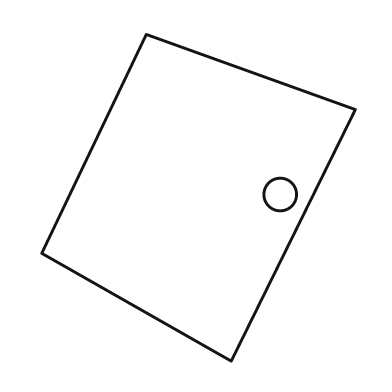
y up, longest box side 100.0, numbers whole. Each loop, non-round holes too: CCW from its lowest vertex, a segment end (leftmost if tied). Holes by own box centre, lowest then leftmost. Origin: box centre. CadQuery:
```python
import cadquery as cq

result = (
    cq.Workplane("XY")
    .moveTo(10.0, -50.0)
    .lineTo(48.0, 27.0)
    .lineTo(-16.0, 50.0)
    .lineTo(-48.0, -17.0)
    .close()
    .moveTo(25.0, 1.0)
    .circle(5.0)
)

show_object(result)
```